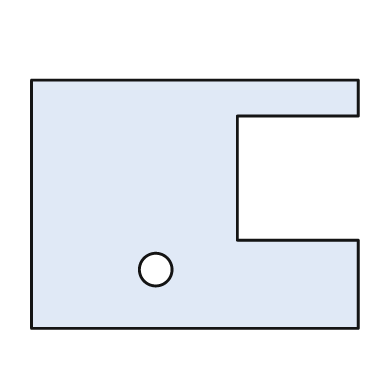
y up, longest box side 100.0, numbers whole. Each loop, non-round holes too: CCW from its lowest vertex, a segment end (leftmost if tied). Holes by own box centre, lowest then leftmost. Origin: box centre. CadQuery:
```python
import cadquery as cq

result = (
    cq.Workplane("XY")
    .moveTo(-50.0, -38.0)
    .lineTo(50.0, -38.0)
    .lineTo(50.0, -11.0)
    .lineTo(13.0, -11.0)
    .lineTo(13.0, 27.0)
    .lineTo(50.0, 27.0)
    .lineTo(50.0, 38.0)
    .lineTo(-50.0, 38.0)
    .close()
    .moveTo(-12.0, -20.0)
    .circle(5.0)
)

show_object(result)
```